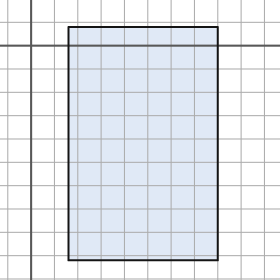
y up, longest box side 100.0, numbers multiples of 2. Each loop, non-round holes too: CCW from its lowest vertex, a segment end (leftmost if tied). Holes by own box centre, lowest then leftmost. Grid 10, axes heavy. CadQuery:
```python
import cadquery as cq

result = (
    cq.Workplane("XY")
    .moveTo(16.0, -92.0)
    .lineTo(80.0, -92.0)
    .lineTo(80.0, 8.0)
    .lineTo(16.0, 8.0)
    .close()
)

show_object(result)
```